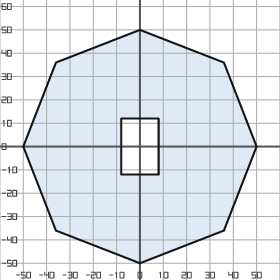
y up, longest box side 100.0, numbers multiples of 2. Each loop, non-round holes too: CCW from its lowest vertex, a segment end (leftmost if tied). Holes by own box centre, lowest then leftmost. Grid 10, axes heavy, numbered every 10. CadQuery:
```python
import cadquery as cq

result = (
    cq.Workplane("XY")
    .moveTo(0.0, -50.0)
    .lineTo(36.0, -36.0)
    .lineTo(50.0, 0.0)
    .lineTo(36.0, 36.0)
    .lineTo(0.0, 50.0)
    .lineTo(-36.0, 36.0)
    .lineTo(-50.0, 0.0)
    .lineTo(-36.0, -36.0)
    .close()
    .moveTo(-8.0, -12.0)
    .lineTo(8.0, -12.0)
    .lineTo(8.0, 12.0)
    .lineTo(-8.0, 12.0)
    .close()
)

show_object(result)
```